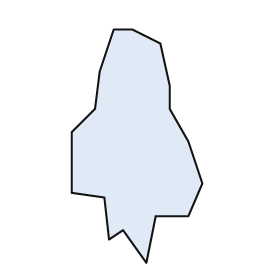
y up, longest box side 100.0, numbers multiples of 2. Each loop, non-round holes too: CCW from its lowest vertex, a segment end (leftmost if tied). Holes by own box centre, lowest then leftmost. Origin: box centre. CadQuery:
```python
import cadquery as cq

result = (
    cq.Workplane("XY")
    .moveTo(4.0, -50.0)
    .lineTo(8.0, -30.0)
    .lineTo(22.0, -30.0)
    .lineTo(28.0, -16.0)
    .lineTo(22.0, 2.0)
    .lineTo(14.0, 16.0)
    .lineTo(14.0, 26.0)
    .lineTo(10.0, 44.0)
    .lineTo(-2.0, 50.0)
    .lineTo(-10.0, 50.0)
    .lineTo(-16.0, 32.0)
    .lineTo(-18.0, 16.0)
    .lineTo(-28.0, 6.0)
    .lineTo(-28.0, -20.0)
    .lineTo(-14.0, -22.0)
    .lineTo(-12.0, -40.0)
    .lineTo(-6.0, -36.0)
    .close()
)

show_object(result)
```